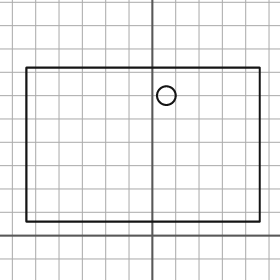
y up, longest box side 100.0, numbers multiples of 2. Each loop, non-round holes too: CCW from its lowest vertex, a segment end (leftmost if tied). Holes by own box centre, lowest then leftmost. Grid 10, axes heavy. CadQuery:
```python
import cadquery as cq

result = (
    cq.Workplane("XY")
    .moveTo(-54.0, 6.0)
    .lineTo(46.0, 6.0)
    .lineTo(46.0, 72.0)
    .lineTo(-54.0, 72.0)
    .close()
    .moveTo(6.0, 60.0)
    .circle(4.0)
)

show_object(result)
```